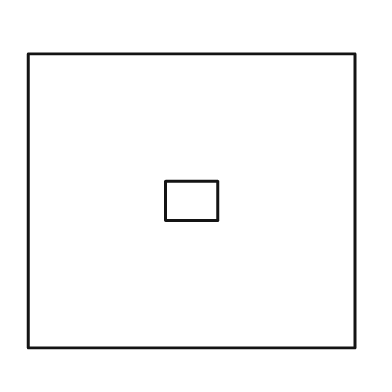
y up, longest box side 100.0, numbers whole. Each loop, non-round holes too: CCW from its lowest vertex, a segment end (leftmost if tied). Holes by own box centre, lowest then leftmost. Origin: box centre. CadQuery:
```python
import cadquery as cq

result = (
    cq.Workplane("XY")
    .moveTo(-50.0, -45.0)
    .lineTo(50.0, -45.0)
    .lineTo(50.0, 45.0)
    .lineTo(-50.0, 45.0)
    .close()
    .moveTo(-8.0, -6.0)
    .lineTo(8.0, -6.0)
    .lineTo(8.0, 6.0)
    .lineTo(-8.0, 6.0)
    .close()
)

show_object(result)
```